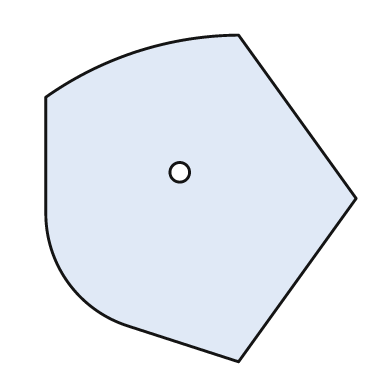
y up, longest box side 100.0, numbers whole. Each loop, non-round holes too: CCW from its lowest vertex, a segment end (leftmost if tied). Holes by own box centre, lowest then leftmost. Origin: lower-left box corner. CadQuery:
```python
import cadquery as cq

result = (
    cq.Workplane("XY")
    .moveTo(59.0, 0.0)
    .lineTo(95.0, 50.0)
    .lineTo(59.0, 100.0)
    .threePointArc((28.0, 95.0), (0.0, 81.0))
    .lineTo(0.0, 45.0)
    .threePointArc((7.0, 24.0), (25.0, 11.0))
    .close()
    .moveTo(41.0, 58.0)
    .circle(3.0)
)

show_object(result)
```